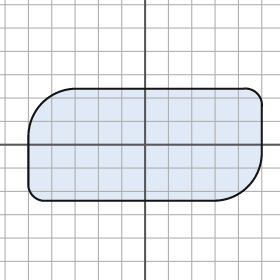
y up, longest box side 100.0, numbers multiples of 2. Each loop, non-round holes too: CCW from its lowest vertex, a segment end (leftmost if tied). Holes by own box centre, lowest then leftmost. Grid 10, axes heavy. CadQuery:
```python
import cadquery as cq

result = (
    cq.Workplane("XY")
    .moveTo(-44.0, -24.0)
    .lineTo(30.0, -24.0)
    .threePointArc((44.0, -18.0), (50.0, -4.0))
    .lineTo(50.0, 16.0)
    .threePointArc((48.0, 22.0), (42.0, 24.0))
    .lineTo(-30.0, 24.0)
    .threePointArc((-44.0, 18.0), (-50.0, 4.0))
    .lineTo(-50.0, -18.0)
    .threePointArc((-48.0, -22.0), (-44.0, -24.0))
    .close()
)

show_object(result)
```